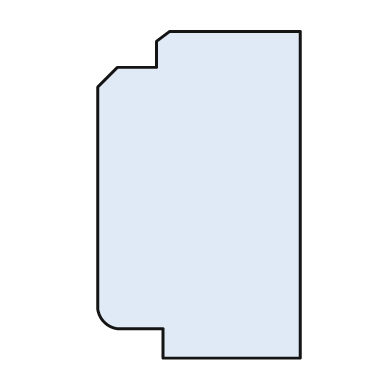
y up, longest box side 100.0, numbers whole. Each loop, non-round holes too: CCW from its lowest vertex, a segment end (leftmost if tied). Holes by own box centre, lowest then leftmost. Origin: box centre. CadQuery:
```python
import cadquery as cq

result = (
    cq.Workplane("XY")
    .moveTo(-11.0, -50.0)
    .lineTo(31.0, -50.0)
    .lineTo(31.0, 50.0)
    .lineTo(-9.0, 50.0)
    .lineTo(-13.0, 47.0)
    .lineTo(-13.0, 39.0)
    .lineTo(-25.0, 39.0)
    .lineTo(-31.0, 33.0)
    .lineTo(-31.0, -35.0)
    .threePointArc((-29.0, -39.0), (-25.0, -41.0))
    .lineTo(-11.0, -41.0)
    .close()
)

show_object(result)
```